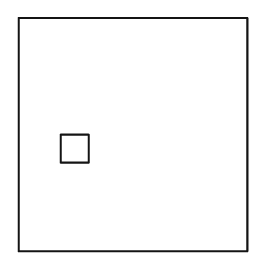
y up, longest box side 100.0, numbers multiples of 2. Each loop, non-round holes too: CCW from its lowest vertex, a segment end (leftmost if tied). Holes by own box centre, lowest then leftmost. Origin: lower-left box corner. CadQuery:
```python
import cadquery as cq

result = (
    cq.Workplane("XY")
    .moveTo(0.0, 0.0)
    .lineTo(98.0, 0.0)
    .lineTo(98.0, 100.0)
    .lineTo(0.0, 100.0)
    .close()
    .moveTo(18.0, 38.0)
    .lineTo(30.0, 38.0)
    .lineTo(30.0, 50.0)
    .lineTo(18.0, 50.0)
    .close()
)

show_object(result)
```